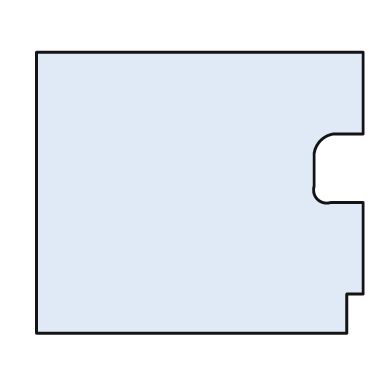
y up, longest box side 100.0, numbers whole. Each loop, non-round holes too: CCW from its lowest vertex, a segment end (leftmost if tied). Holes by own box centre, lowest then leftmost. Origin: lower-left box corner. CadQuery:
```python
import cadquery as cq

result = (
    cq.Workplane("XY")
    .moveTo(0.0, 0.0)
    .lineTo(95.0, 0.0)
    .lineTo(95.0, 12.0)
    .lineTo(100.0, 12.0)
    .lineTo(100.0, 40.0)
    .lineTo(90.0, 40.0)
    .threePointArc((86.0, 41.0), (85.0, 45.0))
    .lineTo(85.0, 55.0)
    .threePointArc((87.0, 59.0), (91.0, 61.0))
    .lineTo(100.0, 61.0)
    .lineTo(100.0, 86.0)
    .lineTo(0.0, 86.0)
    .close()
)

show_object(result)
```